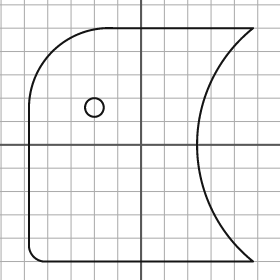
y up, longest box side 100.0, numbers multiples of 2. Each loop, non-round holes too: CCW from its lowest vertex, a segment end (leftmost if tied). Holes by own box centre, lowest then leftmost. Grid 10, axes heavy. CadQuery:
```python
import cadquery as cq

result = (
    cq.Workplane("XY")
    .moveTo(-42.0, -50.0)
    .lineTo(48.0, -50.0)
    .threePointArc((24.0, 0.0), (48.0, 50.0))
    .lineTo(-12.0, 50.0)
    .threePointArc((-38.0, 40.0), (-48.0, 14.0))
    .lineTo(-48.0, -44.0)
    .threePointArc((-46.0, -48.0), (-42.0, -50.0))
    .close()
    .moveTo(-20.0, 16.0)
    .circle(4.0)
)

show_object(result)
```